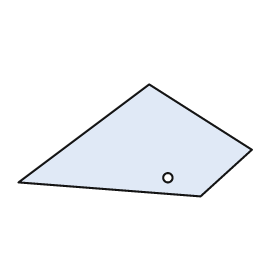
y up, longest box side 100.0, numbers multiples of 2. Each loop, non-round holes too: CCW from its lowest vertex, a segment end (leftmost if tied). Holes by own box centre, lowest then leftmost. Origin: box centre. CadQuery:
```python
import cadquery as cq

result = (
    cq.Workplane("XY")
    .moveTo(28.0, -24.0)
    .lineTo(50.0, -4.0)
    .lineTo(6.0, 24.0)
    .lineTo(-50.0, -18.0)
    .close()
    .moveTo(14.0, -16.0)
    .circle(2.0)
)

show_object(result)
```